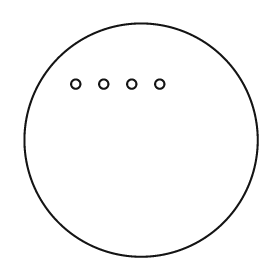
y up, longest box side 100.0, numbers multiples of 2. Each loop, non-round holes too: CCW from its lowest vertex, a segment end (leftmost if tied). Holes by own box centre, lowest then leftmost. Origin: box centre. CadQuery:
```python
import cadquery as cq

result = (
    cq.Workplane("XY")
    .moveTo(0.0, 0.0)
    .circle(50.0)
    .moveTo(-28.0, 24.0)
    .circle(2.0)
    .moveTo(-16.0, 24.0)
    .circle(2.0)
    .moveTo(-4.0, 24.0)
    .circle(2.0)
    .moveTo(8.0, 24.0)
    .circle(2.0)
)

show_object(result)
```